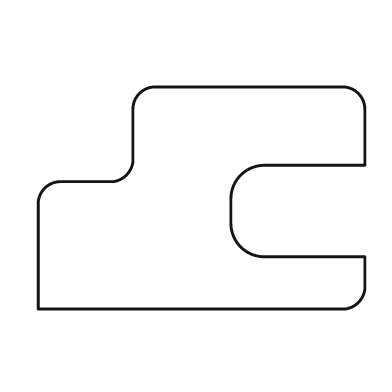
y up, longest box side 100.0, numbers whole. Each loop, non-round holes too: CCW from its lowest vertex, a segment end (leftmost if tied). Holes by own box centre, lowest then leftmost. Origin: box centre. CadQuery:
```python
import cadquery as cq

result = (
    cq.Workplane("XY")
    .moveTo(-50.0, -34.0)
    .lineTo(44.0, -34.0)
    .threePointArc((48.0, -32.0), (50.0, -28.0))
    .lineTo(50.0, -18.0)
    .lineTo(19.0, -18.0)
    .threePointArc((12.0, -15.0), (9.0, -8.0))
    .lineTo(9.0, 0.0)
    .threePointArc((12.0, 7.0), (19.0, 10.0))
    .lineTo(50.0, 10.0)
    .lineTo(50.0, 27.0)
    .threePointArc((48.0, 32.0), (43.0, 34.0))
    .lineTo(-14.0, 34.0)
    .threePointArc((-19.0, 32.0), (-21.0, 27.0))
    .lineTo(-21.0, 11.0)
    .threePointArc((-23.0, 7.0), (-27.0, 5.0))
    .lineTo(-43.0, 5.0)
    .threePointArc((-48.0, 3.0), (-50.0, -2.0))
    .close()
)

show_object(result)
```